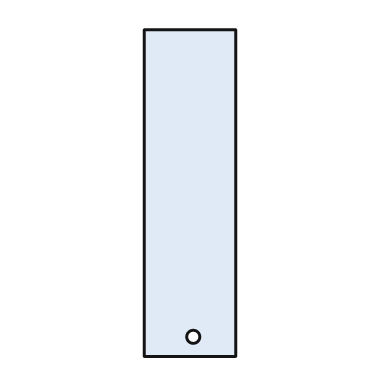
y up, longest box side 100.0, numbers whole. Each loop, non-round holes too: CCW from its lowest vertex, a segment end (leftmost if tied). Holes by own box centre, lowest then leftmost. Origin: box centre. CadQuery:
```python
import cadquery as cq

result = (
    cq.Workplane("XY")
    .moveTo(-14.0, -50.0)
    .lineTo(14.0, -50.0)
    .lineTo(14.0, 50.0)
    .lineTo(-14.0, 50.0)
    .close()
    .moveTo(1.0, -44.0)
    .circle(2.0)
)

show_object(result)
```